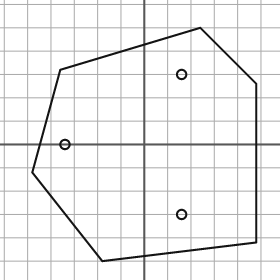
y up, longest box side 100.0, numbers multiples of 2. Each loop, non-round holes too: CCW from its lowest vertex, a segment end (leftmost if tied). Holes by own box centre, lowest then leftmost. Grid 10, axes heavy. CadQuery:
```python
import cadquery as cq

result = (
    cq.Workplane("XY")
    .moveTo(-18.0, -50.0)
    .lineTo(48.0, -42.0)
    .lineTo(48.0, 26.0)
    .lineTo(24.0, 50.0)
    .lineTo(-36.0, 32.0)
    .lineTo(-48.0, -12.0)
    .close()
    .moveTo(16.0, -30.0)
    .circle(2.0)
    .moveTo(-34.0, 0.0)
    .circle(2.0)
    .moveTo(16.0, 30.0)
    .circle(2.0)
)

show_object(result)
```